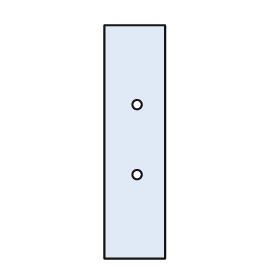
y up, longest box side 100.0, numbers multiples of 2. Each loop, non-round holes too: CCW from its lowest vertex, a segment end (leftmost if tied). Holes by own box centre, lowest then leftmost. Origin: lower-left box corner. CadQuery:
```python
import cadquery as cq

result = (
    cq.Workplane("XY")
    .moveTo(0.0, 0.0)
    .lineTo(26.0, 0.0)
    .lineTo(26.0, 100.0)
    .lineTo(0.0, 100.0)
    .close()
    .moveTo(14.0, 36.0)
    .circle(2.0)
    .moveTo(14.0, 66.0)
    .circle(2.0)
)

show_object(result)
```